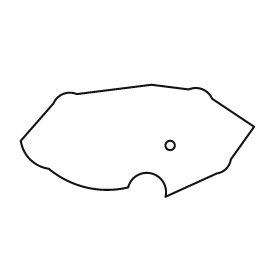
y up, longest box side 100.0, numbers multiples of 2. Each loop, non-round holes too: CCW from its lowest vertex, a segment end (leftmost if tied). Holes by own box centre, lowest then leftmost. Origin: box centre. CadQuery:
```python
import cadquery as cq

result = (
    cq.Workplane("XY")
    .moveTo(12.0, -24.0)
    .lineTo(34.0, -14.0)
    .threePointArc((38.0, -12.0), (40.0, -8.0))
    .lineTo(50.0, 6.0)
    .lineTo(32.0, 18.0)
    .threePointArc((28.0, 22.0), (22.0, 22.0))
    .lineTo(6.0, 24.0)
    .lineTo(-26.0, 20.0)
    .threePointArc((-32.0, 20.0), (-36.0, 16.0))
    .lineTo(-50.0, 0.0)
    .threePointArc((-46.0, -8.0), (-38.0, -12.0))
    .threePointArc((-22.0, -20.0), (-4.0, -20.0))
    .threePointArc((6.0, -14.0), (12.0, -24.0))
    .close()
    .moveTo(14.0, -2.0)
    .circle(2.0)
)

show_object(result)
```